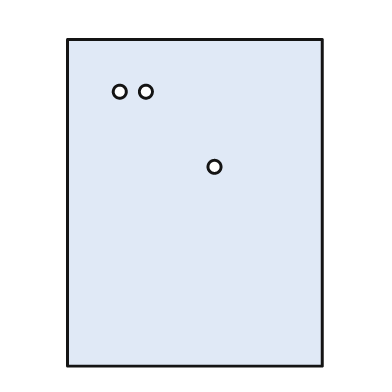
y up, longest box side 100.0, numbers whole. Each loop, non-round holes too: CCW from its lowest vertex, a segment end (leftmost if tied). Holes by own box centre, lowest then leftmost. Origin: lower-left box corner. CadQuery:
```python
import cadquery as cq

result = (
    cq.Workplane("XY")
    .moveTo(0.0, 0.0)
    .lineTo(78.0, 0.0)
    .lineTo(78.0, 100.0)
    .lineTo(0.0, 100.0)
    .close()
    .moveTo(45.0, 61.0)
    .circle(2.0)
    .moveTo(16.0, 84.0)
    .circle(2.0)
    .moveTo(24.0, 84.0)
    .circle(2.0)
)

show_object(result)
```